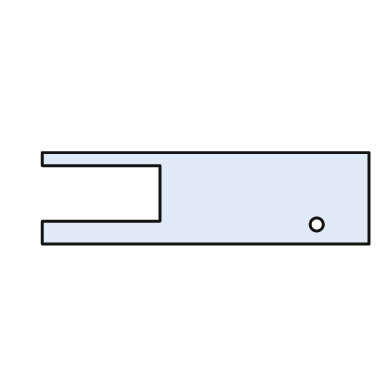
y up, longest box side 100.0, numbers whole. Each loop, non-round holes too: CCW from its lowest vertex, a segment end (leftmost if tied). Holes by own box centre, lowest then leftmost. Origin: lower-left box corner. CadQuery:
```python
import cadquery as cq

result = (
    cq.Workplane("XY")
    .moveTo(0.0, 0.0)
    .lineTo(100.0, 0.0)
    .lineTo(100.0, 28.0)
    .lineTo(0.0, 28.0)
    .lineTo(0.0, 24.0)
    .lineTo(36.0, 24.0)
    .lineTo(36.0, 7.0)
    .lineTo(0.0, 7.0)
    .close()
    .moveTo(84.0, 6.0)
    .circle(2.0)
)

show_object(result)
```